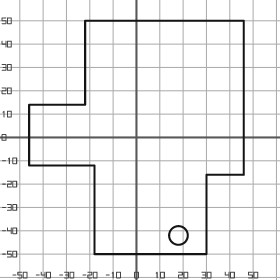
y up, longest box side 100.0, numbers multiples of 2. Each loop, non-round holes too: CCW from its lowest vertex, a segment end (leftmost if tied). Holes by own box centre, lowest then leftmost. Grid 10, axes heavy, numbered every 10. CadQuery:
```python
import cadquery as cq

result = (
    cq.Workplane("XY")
    .moveTo(-18.0, -50.0)
    .lineTo(30.0, -50.0)
    .lineTo(30.0, -16.0)
    .lineTo(46.0, -16.0)
    .lineTo(46.0, 50.0)
    .lineTo(-22.0, 50.0)
    .lineTo(-22.0, 14.0)
    .lineTo(-46.0, 14.0)
    .lineTo(-46.0, -12.0)
    .lineTo(-18.0, -12.0)
    .close()
    .moveTo(18.0, -42.0)
    .circle(4.0)
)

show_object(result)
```